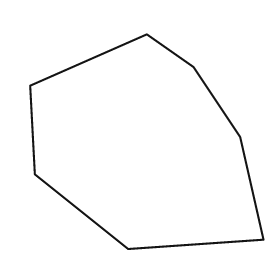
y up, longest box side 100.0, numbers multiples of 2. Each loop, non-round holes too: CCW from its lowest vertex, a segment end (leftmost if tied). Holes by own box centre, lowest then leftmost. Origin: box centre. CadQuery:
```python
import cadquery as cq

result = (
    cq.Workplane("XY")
    .moveTo(-8.0, -46.0)
    .lineTo(50.0, -42.0)
    .lineTo(40.0, 2.0)
    .lineTo(20.0, 32.0)
    .lineTo(0.0, 46.0)
    .lineTo(-50.0, 24.0)
    .lineTo(-48.0, -14.0)
    .close()
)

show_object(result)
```